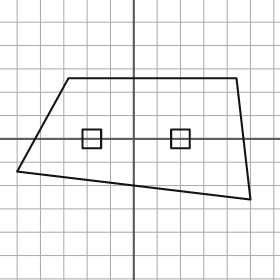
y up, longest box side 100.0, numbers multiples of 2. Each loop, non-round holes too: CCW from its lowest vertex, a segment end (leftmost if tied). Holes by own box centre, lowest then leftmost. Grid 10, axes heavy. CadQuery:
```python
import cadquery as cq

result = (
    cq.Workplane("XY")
    .moveTo(50.0, -26.0)
    .lineTo(44.0, 26.0)
    .lineTo(-28.0, 26.0)
    .lineTo(-50.0, -14.0)
    .close()
    .moveTo(-22.0, -4.0)
    .lineTo(-14.0, -4.0)
    .lineTo(-14.0, 4.0)
    .lineTo(-22.0, 4.0)
    .close()
    .moveTo(16.0, -4.0)
    .lineTo(24.0, -4.0)
    .lineTo(24.0, 4.0)
    .lineTo(16.0, 4.0)
    .close()
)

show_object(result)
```